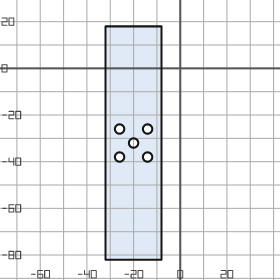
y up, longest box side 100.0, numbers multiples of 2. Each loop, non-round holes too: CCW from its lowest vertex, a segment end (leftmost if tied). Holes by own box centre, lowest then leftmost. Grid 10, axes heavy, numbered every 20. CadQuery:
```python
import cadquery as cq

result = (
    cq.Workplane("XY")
    .moveTo(-32.0, -82.0)
    .lineTo(-8.0, -82.0)
    .lineTo(-8.0, 18.0)
    .lineTo(-32.0, 18.0)
    .close()
    .moveTo(-26.0, -38.0)
    .circle(2.0)
    .moveTo(-14.0, -38.0)
    .circle(2.0)
    .moveTo(-20.0, -32.0)
    .circle(2.0)
    .moveTo(-26.0, -26.0)
    .circle(2.0)
    .moveTo(-14.0, -26.0)
    .circle(2.0)
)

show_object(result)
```